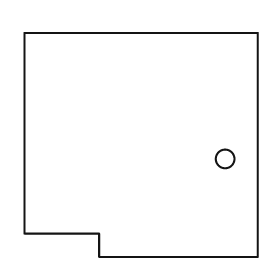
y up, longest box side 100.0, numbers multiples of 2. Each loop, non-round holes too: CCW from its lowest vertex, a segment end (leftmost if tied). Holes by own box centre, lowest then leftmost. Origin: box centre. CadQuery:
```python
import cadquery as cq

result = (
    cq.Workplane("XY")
    .moveTo(-18.0, -48.0)
    .lineTo(50.0, -48.0)
    .lineTo(50.0, 48.0)
    .lineTo(-50.0, 48.0)
    .lineTo(-50.0, -38.0)
    .lineTo(-18.0, -38.0)
    .close()
    .moveTo(36.0, -6.0)
    .circle(4.0)
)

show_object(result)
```